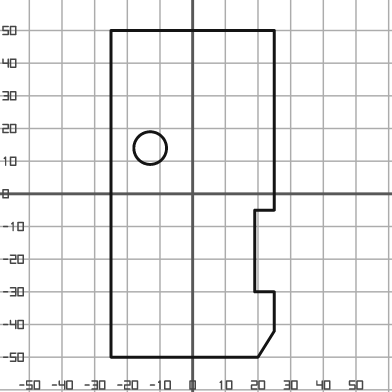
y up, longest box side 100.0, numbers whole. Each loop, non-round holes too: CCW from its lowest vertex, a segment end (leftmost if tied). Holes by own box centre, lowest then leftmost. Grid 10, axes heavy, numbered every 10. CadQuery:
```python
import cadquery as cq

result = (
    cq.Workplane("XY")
    .moveTo(-25.0, -50.0)
    .lineTo(20.0, -50.0)
    .lineTo(25.0, -42.0)
    .lineTo(25.0, -30.0)
    .lineTo(19.0, -30.0)
    .lineTo(19.0, -5.0)
    .lineTo(25.0, -5.0)
    .lineTo(25.0, 50.0)
    .lineTo(-25.0, 50.0)
    .close()
    .moveTo(-13.0, 14.0)
    .circle(5.0)
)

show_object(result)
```